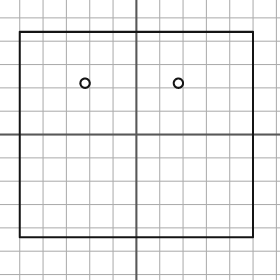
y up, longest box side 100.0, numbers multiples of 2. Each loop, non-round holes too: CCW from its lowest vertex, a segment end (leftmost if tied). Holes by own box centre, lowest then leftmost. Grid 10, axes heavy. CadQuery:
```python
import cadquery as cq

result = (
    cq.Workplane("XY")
    .moveTo(-50.0, -44.0)
    .lineTo(50.0, -44.0)
    .lineTo(50.0, 44.0)
    .lineTo(-50.0, 44.0)
    .close()
    .moveTo(-22.0, 22.0)
    .circle(2.0)
    .moveTo(18.0, 22.0)
    .circle(2.0)
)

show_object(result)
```